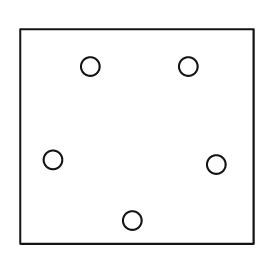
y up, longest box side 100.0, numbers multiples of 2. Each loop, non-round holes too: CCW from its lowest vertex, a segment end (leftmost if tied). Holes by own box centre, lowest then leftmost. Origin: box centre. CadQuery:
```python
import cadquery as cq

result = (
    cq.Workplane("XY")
    .moveTo(-50.0, -46.0)
    .lineTo(50.0, -46.0)
    .lineTo(50.0, 46.0)
    .lineTo(-50.0, 46.0)
    .close()
    .moveTo(-2.0, -36.0)
    .circle(4.0)
    .moveTo(34.0, -12.0)
    .circle(4.0)
    .moveTo(-36.0, -10.0)
    .circle(4.0)
    .moveTo(-20.0, 30.0)
    .circle(4.0)
    .moveTo(22.0, 30.0)
    .circle(4.0)
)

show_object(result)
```